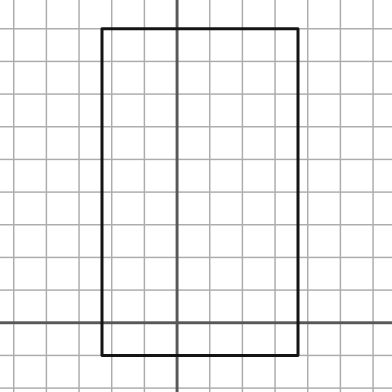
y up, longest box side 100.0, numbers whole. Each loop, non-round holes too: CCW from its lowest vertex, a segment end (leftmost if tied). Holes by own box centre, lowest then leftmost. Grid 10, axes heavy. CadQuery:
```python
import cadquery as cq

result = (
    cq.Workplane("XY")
    .moveTo(-23.0, -10.0)
    .lineTo(37.0, -10.0)
    .lineTo(37.0, 90.0)
    .lineTo(-23.0, 90.0)
    .close()
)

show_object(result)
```